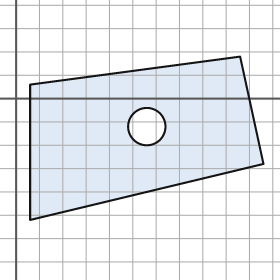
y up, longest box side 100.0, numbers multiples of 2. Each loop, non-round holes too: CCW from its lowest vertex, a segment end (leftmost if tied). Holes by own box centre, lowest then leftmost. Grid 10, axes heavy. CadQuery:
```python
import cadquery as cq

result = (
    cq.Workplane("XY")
    .moveTo(6.0, -52.0)
    .lineTo(106.0, -28.0)
    .lineTo(96.0, 18.0)
    .lineTo(6.0, 6.0)
    .close()
    .moveTo(56.0, -12.0)
    .circle(8.0)
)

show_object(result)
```